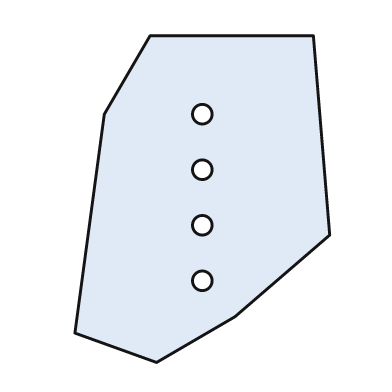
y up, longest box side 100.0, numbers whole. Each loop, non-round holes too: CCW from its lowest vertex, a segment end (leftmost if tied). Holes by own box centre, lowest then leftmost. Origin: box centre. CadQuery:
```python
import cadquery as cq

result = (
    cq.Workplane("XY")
    .moveTo(-14.0, -50.0)
    .lineTo(10.0, -36.0)
    .lineTo(39.0, -11.0)
    .lineTo(34.0, 50.0)
    .lineTo(-16.0, 50.0)
    .lineTo(-30.0, 26.0)
    .lineTo(-39.0, -41.0)
    .close()
    .moveTo(0.0, -25.0)
    .circle(3.0)
    .moveTo(0.0, -8.0)
    .circle(3.0)
    .moveTo(0.0, 9.0)
    .circle(3.0)
    .moveTo(0.0, 26.0)
    .circle(3.0)
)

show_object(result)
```